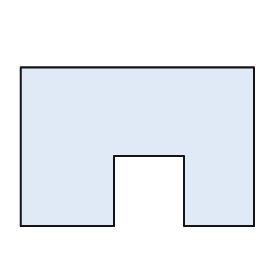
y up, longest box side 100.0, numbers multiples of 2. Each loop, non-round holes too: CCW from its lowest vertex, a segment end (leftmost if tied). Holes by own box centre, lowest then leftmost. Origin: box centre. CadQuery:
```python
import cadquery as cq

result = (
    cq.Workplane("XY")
    .moveTo(-50.0, -34.0)
    .lineTo(-10.0, -34.0)
    .lineTo(-10.0, -4.0)
    .lineTo(20.0, -4.0)
    .lineTo(20.0, -34.0)
    .lineTo(50.0, -34.0)
    .lineTo(50.0, 34.0)
    .lineTo(-50.0, 34.0)
    .close()
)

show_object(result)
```